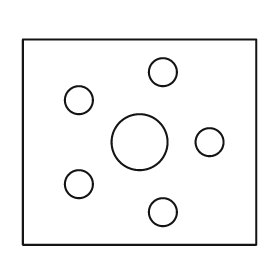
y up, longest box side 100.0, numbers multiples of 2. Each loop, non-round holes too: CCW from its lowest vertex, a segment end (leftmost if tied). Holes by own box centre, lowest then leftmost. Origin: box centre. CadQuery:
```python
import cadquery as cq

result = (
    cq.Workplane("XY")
    .moveTo(-50.0, -44.0)
    .lineTo(50.0, -44.0)
    .lineTo(50.0, 44.0)
    .lineTo(-50.0, 44.0)
    .close()
    .moveTo(10.0, -30.0)
    .circle(6.0)
    .moveTo(-26.0, -18.0)
    .circle(6.0)
    .moveTo(0.0, 0.0)
    .circle(12.0)
    .moveTo(30.0, 0.0)
    .circle(6.0)
    .moveTo(-26.0, 18.0)
    .circle(6.0)
    .moveTo(10.0, 30.0)
    .circle(6.0)
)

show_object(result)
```